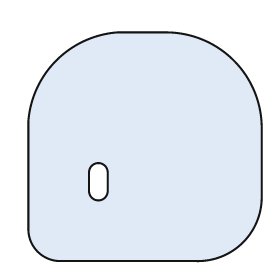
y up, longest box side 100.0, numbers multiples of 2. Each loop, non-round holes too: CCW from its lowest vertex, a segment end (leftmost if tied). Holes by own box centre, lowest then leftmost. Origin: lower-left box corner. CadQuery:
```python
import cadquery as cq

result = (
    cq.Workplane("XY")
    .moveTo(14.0, 0.0)
    .lineTo(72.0, 0.0)
    .threePointArc((92.0, 8.0), (100.0, 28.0))
    .lineTo(100.0, 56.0)
    .threePointArc((88.0, 86.0), (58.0, 98.0))
    .lineTo(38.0, 98.0)
    .threePointArc((12.0, 86.0), (0.0, 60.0))
    .lineTo(0.0, 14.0)
    .threePointArc((4.0, 4.0), (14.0, 0.0))
    .close()
    .moveTo(26.0, 30.0)
    .threePointArc((30.0, 26.0), (34.0, 30.0))
    .lineTo(34.0, 38.0)
    .threePointArc((30.0, 42.0), (26.0, 38.0))
    .close()
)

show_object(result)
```